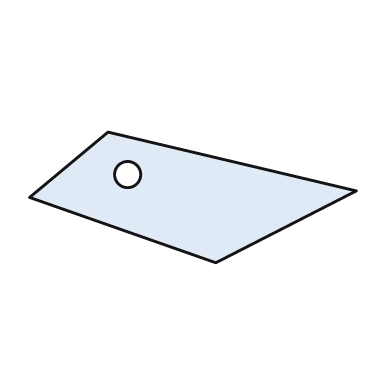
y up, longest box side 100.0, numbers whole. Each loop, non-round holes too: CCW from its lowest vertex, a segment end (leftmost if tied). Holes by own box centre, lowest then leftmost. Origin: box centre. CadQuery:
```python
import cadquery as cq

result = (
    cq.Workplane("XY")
    .moveTo(7.0, -20.0)
    .lineTo(50.0, 2.0)
    .lineTo(-26.0, 20.0)
    .lineTo(-50.0, 0.0)
    .close()
    .moveTo(-20.0, 7.0)
    .circle(4.0)
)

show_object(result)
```